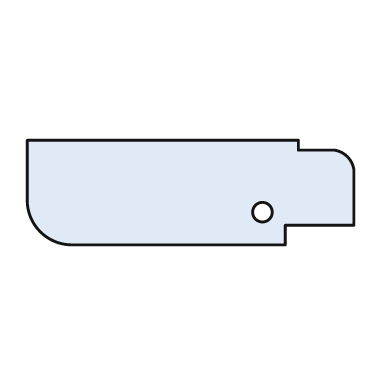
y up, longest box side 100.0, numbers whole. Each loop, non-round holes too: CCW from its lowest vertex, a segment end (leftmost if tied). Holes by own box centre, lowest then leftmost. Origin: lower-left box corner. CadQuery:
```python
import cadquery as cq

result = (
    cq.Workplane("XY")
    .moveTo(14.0, 0.0)
    .lineTo(79.0, 0.0)
    .lineTo(79.0, 6.0)
    .lineTo(100.0, 6.0)
    .lineTo(100.0, 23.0)
    .threePointArc((98.0, 27.0), (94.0, 29.0))
    .lineTo(83.0, 29.0)
    .lineTo(83.0, 32.0)
    .lineTo(0.0, 32.0)
    .lineTo(0.0, 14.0)
    .threePointArc((4.0, 4.0), (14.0, 0.0))
    .close()
    .moveTo(72.0, 10.0)
    .circle(3.0)
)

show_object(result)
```